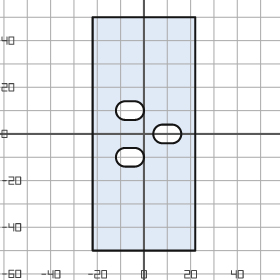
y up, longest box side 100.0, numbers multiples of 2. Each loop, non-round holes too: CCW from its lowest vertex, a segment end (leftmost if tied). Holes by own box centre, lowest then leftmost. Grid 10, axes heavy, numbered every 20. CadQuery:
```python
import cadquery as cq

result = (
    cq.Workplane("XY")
    .moveTo(-22.0, -50.0)
    .lineTo(22.0, -50.0)
    .lineTo(22.0, 50.0)
    .lineTo(-22.0, 50.0)
    .close()
    .moveTo(-8.0, -14.0)
    .lineTo(-4.0, -14.0)
    .threePointArc((0.0, -10.0), (-4.0, -6.0))
    .lineTo(-8.0, -6.0)
    .threePointArc((-12.0, -10.0), (-8.0, -14.0))
    .close()
    .moveTo(8.0, -4.0)
    .lineTo(12.0, -4.0)
    .threePointArc((16.0, 0.0), (12.0, 4.0))
    .lineTo(8.0, 4.0)
    .threePointArc((4.0, 0.0), (8.0, -4.0))
    .close()
    .moveTo(-8.0, 6.0)
    .lineTo(-4.0, 6.0)
    .threePointArc((0.0, 10.0), (-4.0, 14.0))
    .lineTo(-8.0, 14.0)
    .threePointArc((-12.0, 10.0), (-8.0, 6.0))
    .close()
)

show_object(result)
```